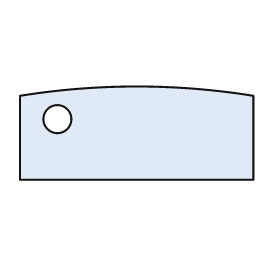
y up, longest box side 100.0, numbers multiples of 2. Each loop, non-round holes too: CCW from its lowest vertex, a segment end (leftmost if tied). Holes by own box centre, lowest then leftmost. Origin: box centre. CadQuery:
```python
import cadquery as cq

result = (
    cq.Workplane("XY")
    .moveTo(-50.0, -20.0)
    .lineTo(50.0, -20.0)
    .lineTo(50.0, 16.0)
    .threePointArc((0.0, 20.0), (-50.0, 16.0))
    .close()
    .moveTo(-34.0, 6.0)
    .circle(6.0)
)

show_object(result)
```